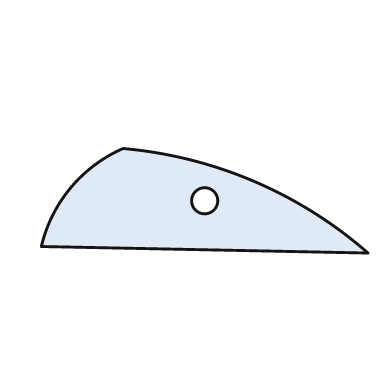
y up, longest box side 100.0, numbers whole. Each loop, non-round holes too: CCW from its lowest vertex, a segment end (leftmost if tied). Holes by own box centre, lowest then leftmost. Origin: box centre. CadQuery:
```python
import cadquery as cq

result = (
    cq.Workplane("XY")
    .moveTo(50.0, -16.0)
    .threePointArc((15.0, 6.0), (-25.0, 16.0))
    .threePointArc((-41.0, 4.0), (-50.0, -14.0))
    .close()
    .moveTo(0.0, 0.0)
    .circle(4.0)
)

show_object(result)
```